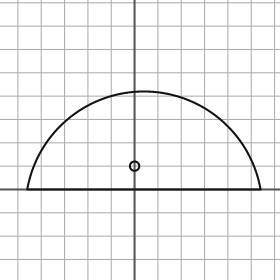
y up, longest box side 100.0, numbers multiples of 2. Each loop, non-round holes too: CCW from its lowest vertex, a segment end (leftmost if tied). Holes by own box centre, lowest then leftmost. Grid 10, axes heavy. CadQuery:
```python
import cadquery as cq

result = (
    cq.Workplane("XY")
    .moveTo(-46.0, 0.0)
    .lineTo(54.0, 0.0)
    .threePointArc((4.0, 42.0), (-46.0, 0.0))
    .close()
    .moveTo(0.0, 10.0)
    .circle(2.0)
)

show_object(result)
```